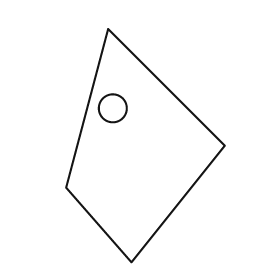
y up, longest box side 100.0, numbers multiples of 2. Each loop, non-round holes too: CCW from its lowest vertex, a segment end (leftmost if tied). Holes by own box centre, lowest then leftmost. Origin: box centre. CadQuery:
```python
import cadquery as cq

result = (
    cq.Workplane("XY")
    .moveTo(-6.0, -50.0)
    .lineTo(34.0, 0.0)
    .lineTo(-16.0, 50.0)
    .lineTo(-34.0, -18.0)
    .close()
    .moveTo(-14.0, 16.0)
    .circle(6.0)
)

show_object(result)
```